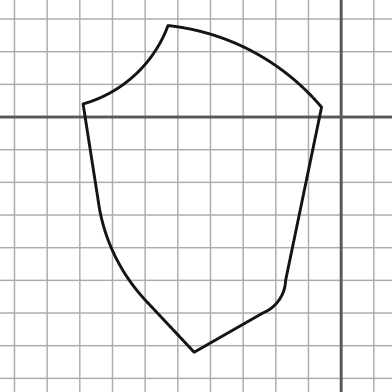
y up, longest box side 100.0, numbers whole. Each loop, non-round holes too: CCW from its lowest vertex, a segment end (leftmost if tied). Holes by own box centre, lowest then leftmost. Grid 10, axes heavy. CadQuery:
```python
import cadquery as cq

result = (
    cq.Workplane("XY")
    .moveTo(-45.0, -72.0)
    .lineTo(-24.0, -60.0)
    .threePointArc((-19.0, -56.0), (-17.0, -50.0))
    .lineTo(-6.0, 3.0)
    .threePointArc((-27.0, 20.0), (-53.0, 28.0))
    .threePointArc((-63.0, 13.0), (-79.0, 4.0))
    .lineTo(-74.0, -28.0)
    .threePointArc((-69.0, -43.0), (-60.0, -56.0))
    .close()
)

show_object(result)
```